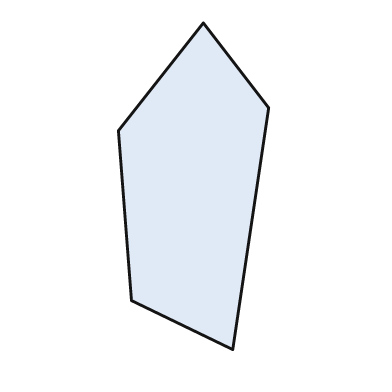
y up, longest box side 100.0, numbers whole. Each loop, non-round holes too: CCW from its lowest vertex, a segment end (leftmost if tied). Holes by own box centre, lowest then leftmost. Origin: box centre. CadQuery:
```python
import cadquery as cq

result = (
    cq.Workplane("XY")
    .moveTo(12.0, -50.0)
    .lineTo(23.0, 24.0)
    .lineTo(3.0, 50.0)
    .lineTo(-23.0, 17.0)
    .lineTo(-19.0, -35.0)
    .close()
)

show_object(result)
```